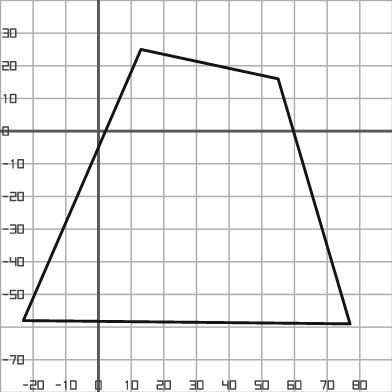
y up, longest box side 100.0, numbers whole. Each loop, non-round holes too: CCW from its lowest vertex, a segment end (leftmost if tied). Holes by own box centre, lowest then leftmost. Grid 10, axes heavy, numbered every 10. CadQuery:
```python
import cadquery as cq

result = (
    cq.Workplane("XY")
    .moveTo(77.0, -59.0)
    .lineTo(55.0, 16.0)
    .lineTo(13.0, 25.0)
    .lineTo(-23.0, -58.0)
    .close()
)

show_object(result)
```